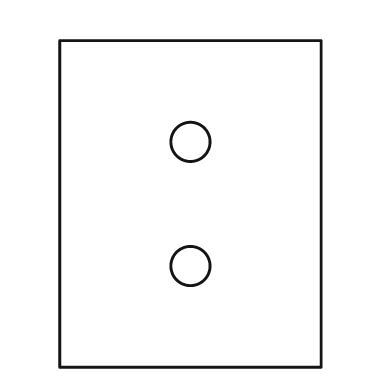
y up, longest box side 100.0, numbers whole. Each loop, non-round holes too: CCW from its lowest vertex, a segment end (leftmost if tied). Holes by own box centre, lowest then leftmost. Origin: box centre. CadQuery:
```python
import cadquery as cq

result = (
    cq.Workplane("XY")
    .moveTo(-40.0, -50.0)
    .lineTo(40.0, -50.0)
    .lineTo(40.0, 50.0)
    .lineTo(-40.0, 50.0)
    .close()
    .moveTo(0.0, -19.0)
    .circle(6.0)
    .moveTo(0.0, 19.0)
    .circle(6.0)
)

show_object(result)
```